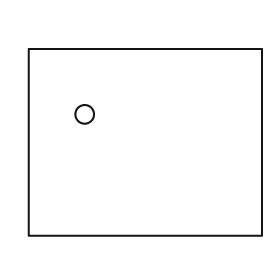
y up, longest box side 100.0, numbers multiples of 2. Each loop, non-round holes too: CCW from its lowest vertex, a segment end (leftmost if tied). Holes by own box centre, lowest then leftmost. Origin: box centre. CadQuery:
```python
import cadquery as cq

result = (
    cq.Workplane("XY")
    .moveTo(-50.0, -40.0)
    .lineTo(50.0, -40.0)
    .lineTo(50.0, 40.0)
    .lineTo(-50.0, 40.0)
    .close()
    .moveTo(-26.0, 12.0)
    .circle(4.0)
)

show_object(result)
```